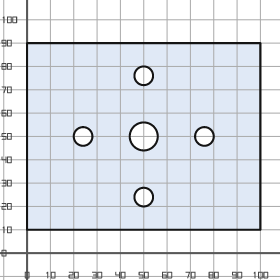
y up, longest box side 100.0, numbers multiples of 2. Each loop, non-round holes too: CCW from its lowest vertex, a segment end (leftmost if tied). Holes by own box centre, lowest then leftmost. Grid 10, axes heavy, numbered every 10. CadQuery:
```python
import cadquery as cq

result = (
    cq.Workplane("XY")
    .moveTo(0.0, 10.0)
    .lineTo(100.0, 10.0)
    .lineTo(100.0, 90.0)
    .lineTo(0.0, 90.0)
    .close()
    .moveTo(50.0, 24.0)
    .circle(4.0)
    .moveTo(24.0, 50.0)
    .circle(4.0)
    .moveTo(50.0, 50.0)
    .circle(6.0)
    .moveTo(76.0, 50.0)
    .circle(4.0)
    .moveTo(50.0, 76.0)
    .circle(4.0)
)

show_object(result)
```